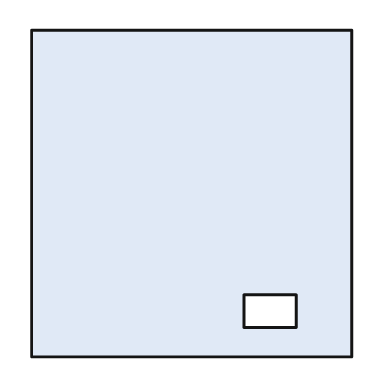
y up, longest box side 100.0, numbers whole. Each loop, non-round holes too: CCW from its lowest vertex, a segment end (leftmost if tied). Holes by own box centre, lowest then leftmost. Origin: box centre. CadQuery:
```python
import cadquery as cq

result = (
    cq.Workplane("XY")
    .moveTo(-49.0, -50.0)
    .lineTo(49.0, -50.0)
    .lineTo(49.0, 50.0)
    .lineTo(-49.0, 50.0)
    .close()
    .moveTo(16.0, -41.0)
    .lineTo(32.0, -41.0)
    .lineTo(32.0, -31.0)
    .lineTo(16.0, -31.0)
    .close()
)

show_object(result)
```